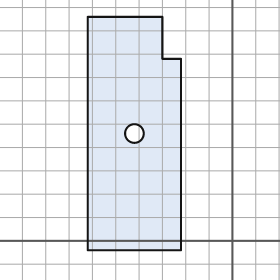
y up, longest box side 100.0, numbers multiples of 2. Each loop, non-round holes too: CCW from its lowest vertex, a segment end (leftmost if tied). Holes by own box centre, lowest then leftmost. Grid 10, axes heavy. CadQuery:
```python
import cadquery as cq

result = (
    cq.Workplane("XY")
    .moveTo(-62.0, -4.0)
    .lineTo(-22.0, -4.0)
    .lineTo(-22.0, 78.0)
    .lineTo(-30.0, 78.0)
    .lineTo(-30.0, 96.0)
    .lineTo(-62.0, 96.0)
    .close()
    .moveTo(-42.0, 46.0)
    .circle(4.0)
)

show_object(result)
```